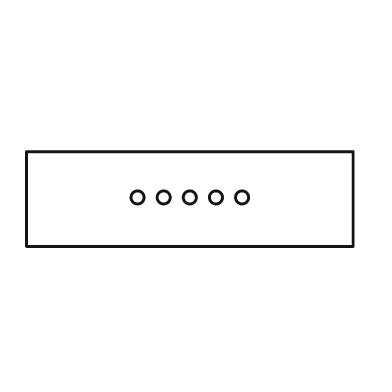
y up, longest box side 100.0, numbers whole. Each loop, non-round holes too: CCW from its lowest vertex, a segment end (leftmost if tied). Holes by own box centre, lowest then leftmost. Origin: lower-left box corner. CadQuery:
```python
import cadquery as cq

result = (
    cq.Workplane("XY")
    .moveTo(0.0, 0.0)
    .lineTo(100.0, 0.0)
    .lineTo(100.0, 29.0)
    .lineTo(0.0, 29.0)
    .close()
    .moveTo(34.0, 15.0)
    .circle(2.0)
    .moveTo(42.0, 15.0)
    .circle(2.0)
    .moveTo(50.0, 15.0)
    .circle(2.0)
    .moveTo(58.0, 15.0)
    .circle(2.0)
    .moveTo(66.0, 15.0)
    .circle(2.0)
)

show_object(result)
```